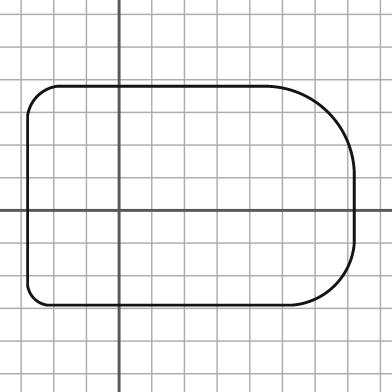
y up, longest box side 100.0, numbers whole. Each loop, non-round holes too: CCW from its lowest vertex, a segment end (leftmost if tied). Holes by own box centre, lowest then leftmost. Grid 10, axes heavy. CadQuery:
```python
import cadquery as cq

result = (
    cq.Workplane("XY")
    .moveTo(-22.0, -29.0)
    .lineTo(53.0, -29.0)
    .threePointArc((66.0, -23.0), (72.0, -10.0))
    .lineTo(72.0, 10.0)
    .threePointArc((64.0, 30.0), (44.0, 38.0))
    .lineTo(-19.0, 38.0)
    .threePointArc((-25.0, 35.0), (-28.0, 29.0))
    .lineTo(-28.0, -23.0)
    .threePointArc((-26.0, -27.0), (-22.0, -29.0))
    .close()
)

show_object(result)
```